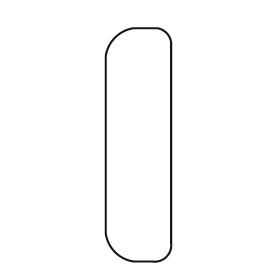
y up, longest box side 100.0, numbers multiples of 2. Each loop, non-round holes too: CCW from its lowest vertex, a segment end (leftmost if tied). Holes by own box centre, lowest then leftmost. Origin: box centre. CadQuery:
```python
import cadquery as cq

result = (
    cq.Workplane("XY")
    .moveTo(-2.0, -50.0)
    .lineTo(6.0, -50.0)
    .threePointArc((12.0, -48.0), (14.0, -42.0))
    .lineTo(14.0, 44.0)
    .threePointArc((12.0, 48.0), (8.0, 50.0))
    .lineTo(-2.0, 50.0)
    .threePointArc((-10.0, 46.0), (-14.0, 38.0))
    .lineTo(-14.0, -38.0)
    .threePointArc((-10.0, -46.0), (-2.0, -50.0))
    .close()
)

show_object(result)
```